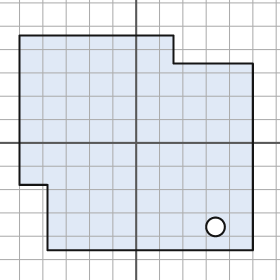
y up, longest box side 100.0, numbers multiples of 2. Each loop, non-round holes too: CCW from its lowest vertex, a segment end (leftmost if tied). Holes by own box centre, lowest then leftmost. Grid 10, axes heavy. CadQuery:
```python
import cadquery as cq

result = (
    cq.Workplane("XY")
    .moveTo(-38.0, -46.0)
    .lineTo(50.0, -46.0)
    .lineTo(50.0, 34.0)
    .lineTo(16.0, 34.0)
    .lineTo(16.0, 46.0)
    .lineTo(-50.0, 46.0)
    .lineTo(-50.0, -18.0)
    .lineTo(-38.0, -18.0)
    .close()
    .moveTo(34.0, -36.0)
    .circle(4.0)
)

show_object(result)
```